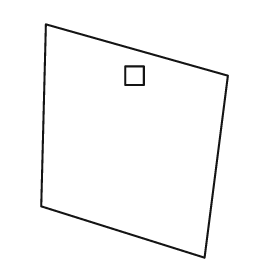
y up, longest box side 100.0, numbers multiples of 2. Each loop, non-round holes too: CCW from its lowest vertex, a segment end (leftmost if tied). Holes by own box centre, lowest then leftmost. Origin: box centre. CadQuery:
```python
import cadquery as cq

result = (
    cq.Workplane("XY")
    .moveTo(30.0, -50.0)
    .lineTo(40.0, 28.0)
    .lineTo(-38.0, 50.0)
    .lineTo(-40.0, -28.0)
    .close()
    .moveTo(-4.0, 24.0)
    .lineTo(4.0, 24.0)
    .lineTo(4.0, 32.0)
    .lineTo(-4.0, 32.0)
    .close()
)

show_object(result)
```